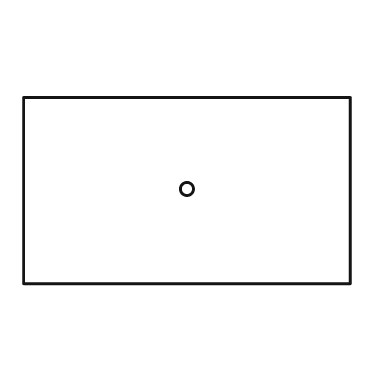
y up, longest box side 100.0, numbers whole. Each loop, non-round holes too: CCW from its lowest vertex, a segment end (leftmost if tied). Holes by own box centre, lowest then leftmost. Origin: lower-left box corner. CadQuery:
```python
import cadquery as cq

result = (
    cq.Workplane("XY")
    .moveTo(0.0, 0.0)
    .lineTo(100.0, 0.0)
    .lineTo(100.0, 57.0)
    .lineTo(0.0, 57.0)
    .close()
    .moveTo(50.0, 29.0)
    .circle(2.0)
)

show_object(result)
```